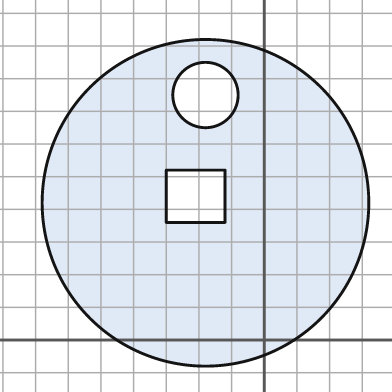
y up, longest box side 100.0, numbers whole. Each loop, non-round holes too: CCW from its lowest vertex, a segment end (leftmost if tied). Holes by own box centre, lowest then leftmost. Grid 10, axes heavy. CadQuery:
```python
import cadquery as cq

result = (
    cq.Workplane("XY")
    .moveTo(-18.0, 42.0)
    .circle(50.0)
    .moveTo(-30.0, 36.0)
    .lineTo(-12.0, 36.0)
    .lineTo(-12.0, 52.0)
    .lineTo(-30.0, 52.0)
    .close()
    .moveTo(-18.0, 75.0)
    .circle(10.0)
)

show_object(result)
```